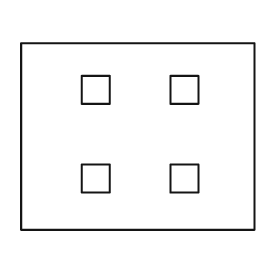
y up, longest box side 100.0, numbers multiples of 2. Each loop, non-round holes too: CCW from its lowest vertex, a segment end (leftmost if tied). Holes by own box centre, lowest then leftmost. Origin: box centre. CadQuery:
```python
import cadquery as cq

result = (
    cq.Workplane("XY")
    .moveTo(-50.0, -40.0)
    .lineTo(50.0, -40.0)
    .lineTo(50.0, 40.0)
    .lineTo(-50.0, 40.0)
    .close()
    .moveTo(-24.0, -24.0)
    .lineTo(-12.0, -24.0)
    .lineTo(-12.0, -12.0)
    .lineTo(-24.0, -12.0)
    .close()
    .moveTo(14.0, -24.0)
    .lineTo(26.0, -24.0)
    .lineTo(26.0, -12.0)
    .lineTo(14.0, -12.0)
    .close()
    .moveTo(-24.0, 14.0)
    .lineTo(-12.0, 14.0)
    .lineTo(-12.0, 26.0)
    .lineTo(-24.0, 26.0)
    .close()
    .moveTo(14.0, 14.0)
    .lineTo(26.0, 14.0)
    .lineTo(26.0, 26.0)
    .lineTo(14.0, 26.0)
    .close()
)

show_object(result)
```